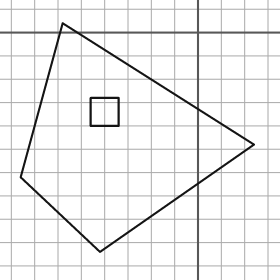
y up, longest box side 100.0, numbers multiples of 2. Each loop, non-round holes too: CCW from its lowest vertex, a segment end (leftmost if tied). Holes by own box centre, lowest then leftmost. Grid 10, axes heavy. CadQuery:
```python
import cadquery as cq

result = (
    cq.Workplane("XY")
    .moveTo(-42.0, -94.0)
    .lineTo(24.0, -48.0)
    .lineTo(-58.0, 4.0)
    .lineTo(-76.0, -62.0)
    .close()
    .moveTo(-46.0, -40.0)
    .lineTo(-34.0, -40.0)
    .lineTo(-34.0, -28.0)
    .lineTo(-46.0, -28.0)
    .close()
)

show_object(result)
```